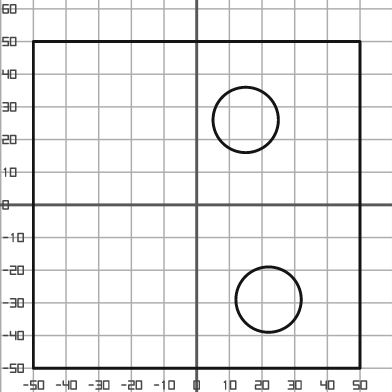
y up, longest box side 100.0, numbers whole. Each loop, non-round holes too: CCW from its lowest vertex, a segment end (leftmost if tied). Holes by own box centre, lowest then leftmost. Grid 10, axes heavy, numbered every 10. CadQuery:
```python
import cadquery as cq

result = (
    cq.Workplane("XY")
    .moveTo(-50.0, -50.0)
    .lineTo(50.0, -50.0)
    .lineTo(50.0, 50.0)
    .lineTo(-50.0, 50.0)
    .close()
    .moveTo(22.0, -29.0)
    .circle(10.0)
    .moveTo(15.0, 26.0)
    .circle(10.0)
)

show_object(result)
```